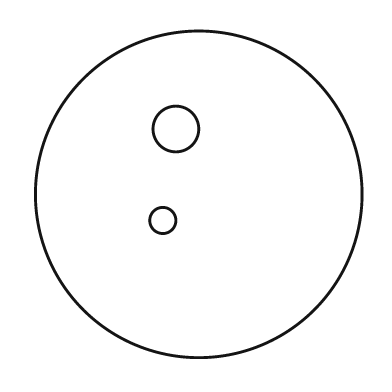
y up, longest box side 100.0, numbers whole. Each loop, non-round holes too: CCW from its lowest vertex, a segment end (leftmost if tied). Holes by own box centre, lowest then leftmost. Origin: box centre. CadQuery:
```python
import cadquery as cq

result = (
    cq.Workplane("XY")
    .moveTo(0.0, 0.0)
    .circle(50.0)
    .moveTo(-11.0, -8.0)
    .circle(4.0)
    .moveTo(-7.0, 20.0)
    .circle(7.0)
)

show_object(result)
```